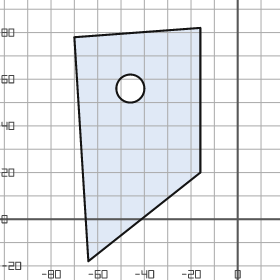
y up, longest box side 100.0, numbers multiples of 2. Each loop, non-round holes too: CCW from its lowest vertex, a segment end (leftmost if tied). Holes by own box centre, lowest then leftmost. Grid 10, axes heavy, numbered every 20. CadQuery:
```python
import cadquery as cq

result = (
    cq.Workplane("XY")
    .moveTo(-64.0, -18.0)
    .lineTo(-16.0, 20.0)
    .lineTo(-16.0, 82.0)
    .lineTo(-70.0, 78.0)
    .close()
    .moveTo(-46.0, 56.0)
    .circle(6.0)
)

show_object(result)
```